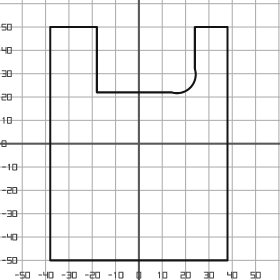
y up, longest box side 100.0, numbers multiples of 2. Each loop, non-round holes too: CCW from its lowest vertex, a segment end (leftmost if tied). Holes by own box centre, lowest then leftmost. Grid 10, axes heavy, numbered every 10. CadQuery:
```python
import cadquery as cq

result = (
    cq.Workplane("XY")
    .moveTo(-38.0, -50.0)
    .lineTo(38.0, -50.0)
    .lineTo(38.0, 50.0)
    .lineTo(24.0, 50.0)
    .lineTo(24.0, 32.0)
    .threePointArc((22.0, 24.0), (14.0, 22.0))
    .lineTo(-18.0, 22.0)
    .lineTo(-18.0, 50.0)
    .lineTo(-38.0, 50.0)
    .close()
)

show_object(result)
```